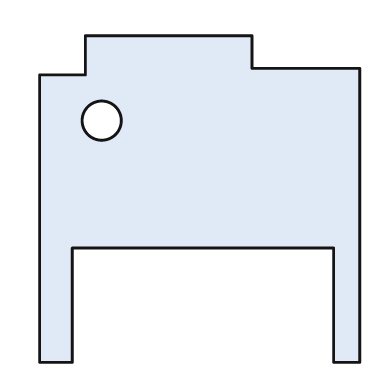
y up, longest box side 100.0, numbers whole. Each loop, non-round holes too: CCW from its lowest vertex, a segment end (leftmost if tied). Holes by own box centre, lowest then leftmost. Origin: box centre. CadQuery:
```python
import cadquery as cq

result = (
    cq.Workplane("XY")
    .moveTo(-49.0, -50.0)
    .lineTo(-39.0, -50.0)
    .lineTo(-39.0, -15.0)
    .lineTo(41.0, -15.0)
    .lineTo(41.0, -50.0)
    .lineTo(49.0, -50.0)
    .lineTo(49.0, 40.0)
    .lineTo(16.0, 40.0)
    .lineTo(16.0, 50.0)
    .lineTo(-35.0, 50.0)
    .lineTo(-35.0, 38.0)
    .lineTo(-49.0, 38.0)
    .close()
    .moveTo(-30.0, 24.0)
    .circle(6.0)
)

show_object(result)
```